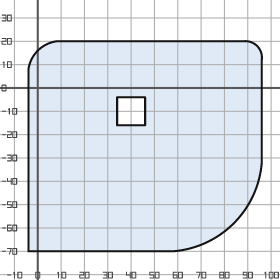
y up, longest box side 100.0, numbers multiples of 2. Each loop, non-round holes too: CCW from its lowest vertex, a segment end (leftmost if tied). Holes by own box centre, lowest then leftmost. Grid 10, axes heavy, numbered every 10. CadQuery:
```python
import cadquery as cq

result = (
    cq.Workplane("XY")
    .moveTo(-4.0, -70.0)
    .lineTo(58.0, -70.0)
    .threePointArc((84.0, -58.0), (96.0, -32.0))
    .lineTo(96.0, 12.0)
    .threePointArc((94.0, 18.0), (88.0, 20.0))
    .lineTo(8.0, 20.0)
    .threePointArc((0.0, 16.0), (-4.0, 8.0))
    .close()
    .moveTo(34.0, -16.0)
    .lineTo(46.0, -16.0)
    .lineTo(46.0, -4.0)
    .lineTo(34.0, -4.0)
    .close()
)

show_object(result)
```